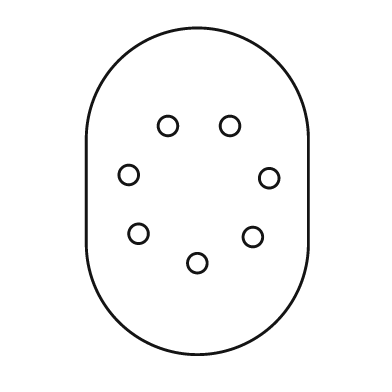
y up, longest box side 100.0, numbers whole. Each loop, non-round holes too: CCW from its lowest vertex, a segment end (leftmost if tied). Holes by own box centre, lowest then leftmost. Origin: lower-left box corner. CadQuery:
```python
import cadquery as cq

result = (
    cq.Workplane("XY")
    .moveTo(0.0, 34.0)
    .threePointArc((34.0, 0.0), (68.0, 34.0))
    .lineTo(68.0, 66.0)
    .threePointArc((34.0, 100.0), (0.0, 66.0))
    .close()
    .moveTo(34.0, 28.0)
    .circle(3.0)
    .moveTo(51.0, 36.0)
    .circle(3.0)
    .moveTo(16.0, 37.0)
    .circle(3.0)
    .moveTo(56.0, 54.0)
    .circle(3.0)
    .moveTo(13.0, 55.0)
    .circle(3.0)
    .moveTo(25.0, 70.0)
    .circle(3.0)
    .moveTo(44.0, 70.0)
    .circle(3.0)
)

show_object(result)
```